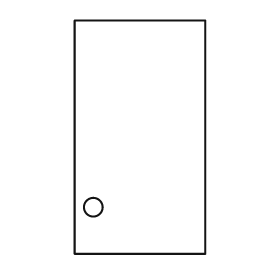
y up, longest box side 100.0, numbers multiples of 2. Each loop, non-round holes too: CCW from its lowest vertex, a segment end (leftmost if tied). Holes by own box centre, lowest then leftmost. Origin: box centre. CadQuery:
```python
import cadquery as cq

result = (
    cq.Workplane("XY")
    .moveTo(-28.0, -50.0)
    .lineTo(28.0, -50.0)
    .lineTo(28.0, 50.0)
    .lineTo(-28.0, 50.0)
    .close()
    .moveTo(-20.0, -30.0)
    .circle(4.0)
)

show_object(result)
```